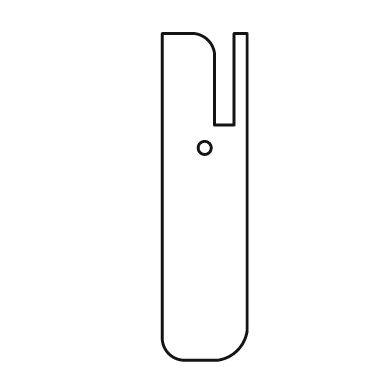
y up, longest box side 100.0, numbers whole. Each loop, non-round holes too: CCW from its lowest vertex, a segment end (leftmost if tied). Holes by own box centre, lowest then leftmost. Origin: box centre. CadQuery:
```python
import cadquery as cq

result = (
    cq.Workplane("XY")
    .moveTo(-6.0, -50.0)
    .lineTo(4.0, -50.0)
    .threePointArc((10.0, -47.0), (13.0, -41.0))
    .lineTo(13.0, 50.0)
    .lineTo(9.0, 50.0)
    .lineTo(9.0, 22.0)
    .lineTo(3.0, 22.0)
    .lineTo(3.0, 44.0)
    .threePointArc((1.0, 48.0), (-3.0, 50.0))
    .lineTo(-13.0, 50.0)
    .lineTo(-13.0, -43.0)
    .threePointArc((-11.0, -48.0), (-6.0, -50.0))
    .close()
    .moveTo(0.0, 15.0)
    .circle(2.0)
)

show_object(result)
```